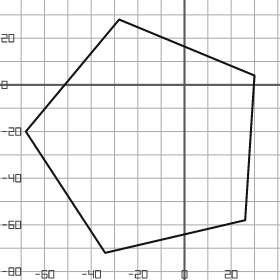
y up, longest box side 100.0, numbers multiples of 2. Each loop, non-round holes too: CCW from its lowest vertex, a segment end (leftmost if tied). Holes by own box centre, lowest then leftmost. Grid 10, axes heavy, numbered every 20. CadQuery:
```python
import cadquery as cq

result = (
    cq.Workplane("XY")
    .moveTo(-34.0, -72.0)
    .lineTo(26.0, -58.0)
    .lineTo(30.0, 4.0)
    .lineTo(-28.0, 28.0)
    .lineTo(-68.0, -20.0)
    .close()
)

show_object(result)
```